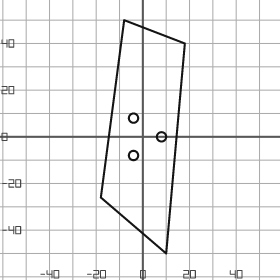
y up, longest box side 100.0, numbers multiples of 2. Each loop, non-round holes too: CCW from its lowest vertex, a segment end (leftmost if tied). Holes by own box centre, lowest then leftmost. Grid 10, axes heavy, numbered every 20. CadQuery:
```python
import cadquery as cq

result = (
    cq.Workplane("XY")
    .moveTo(10.0, -50.0)
    .lineTo(18.0, 40.0)
    .lineTo(-8.0, 50.0)
    .lineTo(-18.0, -26.0)
    .close()
    .moveTo(-4.0, -8.0)
    .circle(2.0)
    .moveTo(8.0, 0.0)
    .circle(2.0)
    .moveTo(-4.0, 8.0)
    .circle(2.0)
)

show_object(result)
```